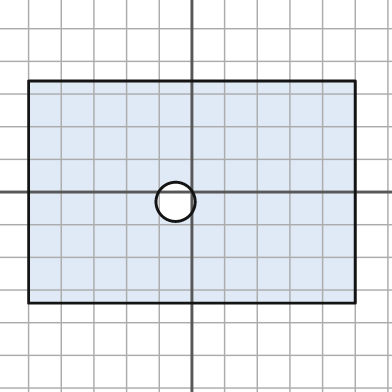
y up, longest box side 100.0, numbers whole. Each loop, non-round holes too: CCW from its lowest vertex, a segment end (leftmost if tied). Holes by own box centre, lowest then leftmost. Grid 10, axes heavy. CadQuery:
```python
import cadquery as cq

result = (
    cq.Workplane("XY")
    .moveTo(-50.0, -34.0)
    .lineTo(50.0, -34.0)
    .lineTo(50.0, 34.0)
    .lineTo(-50.0, 34.0)
    .close()
    .moveTo(-5.0, -3.0)
    .circle(6.0)
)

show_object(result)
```